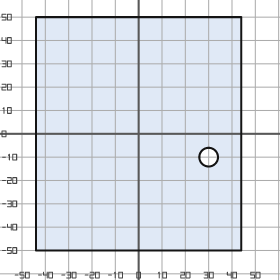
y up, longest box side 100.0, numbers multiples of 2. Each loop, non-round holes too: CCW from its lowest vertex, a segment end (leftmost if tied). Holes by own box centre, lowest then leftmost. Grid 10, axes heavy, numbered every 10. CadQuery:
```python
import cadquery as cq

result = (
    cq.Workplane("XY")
    .moveTo(-44.0, -50.0)
    .lineTo(44.0, -50.0)
    .lineTo(44.0, 50.0)
    .lineTo(-44.0, 50.0)
    .close()
    .moveTo(30.0, -10.0)
    .circle(4.0)
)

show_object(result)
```